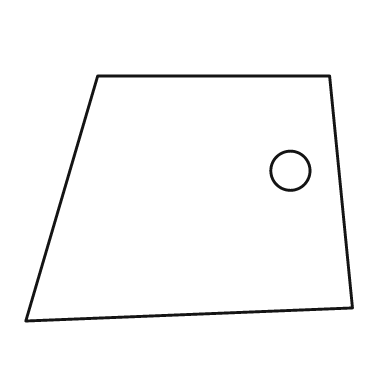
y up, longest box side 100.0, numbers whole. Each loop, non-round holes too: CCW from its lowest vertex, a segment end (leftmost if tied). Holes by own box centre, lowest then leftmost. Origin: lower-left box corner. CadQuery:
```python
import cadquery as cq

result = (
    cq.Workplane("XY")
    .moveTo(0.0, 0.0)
    .lineTo(100.0, 4.0)
    .lineTo(93.0, 75.0)
    .lineTo(22.0, 75.0)
    .close()
    .moveTo(81.0, 46.0)
    .circle(6.0)
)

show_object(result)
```